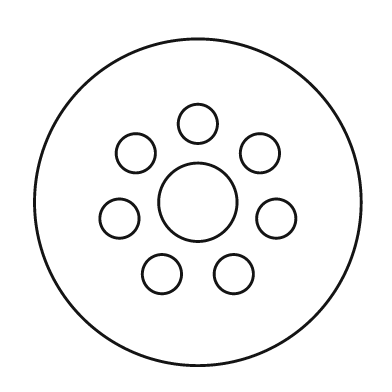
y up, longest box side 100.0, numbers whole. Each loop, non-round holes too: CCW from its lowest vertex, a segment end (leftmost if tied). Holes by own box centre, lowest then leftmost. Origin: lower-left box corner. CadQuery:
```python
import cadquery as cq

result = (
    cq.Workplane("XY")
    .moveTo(50.0, 50.0)
    .circle(50.0)
    .moveTo(39.0, 28.0)
    .circle(6.0)
    .moveTo(61.0, 28.0)
    .circle(6.0)
    .moveTo(26.0, 45.0)
    .circle(6.0)
    .moveTo(74.0, 45.0)
    .circle(6.0)
    .moveTo(50.0, 50.0)
    .circle(12.0)
    .moveTo(31.0, 65.0)
    .circle(6.0)
    .moveTo(69.0, 65.0)
    .circle(6.0)
    .moveTo(50.0, 74.0)
    .circle(6.0)
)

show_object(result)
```